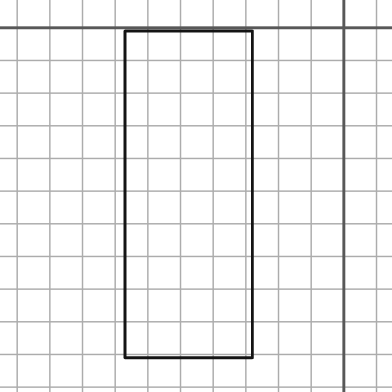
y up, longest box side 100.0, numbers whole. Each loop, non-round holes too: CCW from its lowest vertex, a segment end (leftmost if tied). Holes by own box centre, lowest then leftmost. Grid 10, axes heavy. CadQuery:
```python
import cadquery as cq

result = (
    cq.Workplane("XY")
    .moveTo(-67.0, -101.0)
    .lineTo(-28.0, -101.0)
    .lineTo(-28.0, -1.0)
    .lineTo(-67.0, -1.0)
    .close()
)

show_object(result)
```